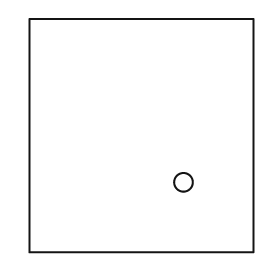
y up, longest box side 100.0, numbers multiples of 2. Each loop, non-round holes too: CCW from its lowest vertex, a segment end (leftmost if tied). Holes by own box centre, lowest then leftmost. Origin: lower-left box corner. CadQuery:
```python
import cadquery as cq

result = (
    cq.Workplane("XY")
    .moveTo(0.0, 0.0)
    .lineTo(96.0, 0.0)
    .lineTo(96.0, 100.0)
    .lineTo(0.0, 100.0)
    .close()
    .moveTo(66.0, 30.0)
    .circle(4.0)
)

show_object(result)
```